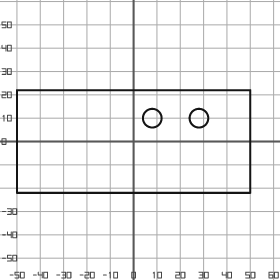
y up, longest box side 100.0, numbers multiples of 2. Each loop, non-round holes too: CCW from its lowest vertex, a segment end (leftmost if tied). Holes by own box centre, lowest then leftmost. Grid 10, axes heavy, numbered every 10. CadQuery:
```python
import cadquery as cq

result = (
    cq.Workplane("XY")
    .moveTo(-50.0, -22.0)
    .lineTo(50.0, -22.0)
    .lineTo(50.0, 22.0)
    .lineTo(-50.0, 22.0)
    .close()
    .moveTo(8.0, 10.0)
    .circle(4.0)
    .moveTo(28.0, 10.0)
    .circle(4.0)
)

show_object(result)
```